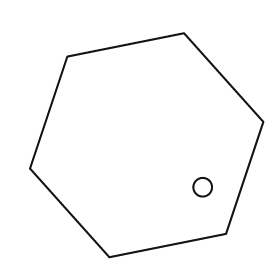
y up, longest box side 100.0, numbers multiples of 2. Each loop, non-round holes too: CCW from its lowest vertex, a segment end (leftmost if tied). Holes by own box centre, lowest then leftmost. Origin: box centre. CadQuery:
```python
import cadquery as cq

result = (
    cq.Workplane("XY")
    .moveTo(-16.0, -48.0)
    .lineTo(34.0, -38.0)
    .lineTo(50.0, 10.0)
    .lineTo(16.0, 48.0)
    .lineTo(-34.0, 38.0)
    .lineTo(-50.0, -10.0)
    .close()
    .moveTo(24.0, -18.0)
    .circle(4.0)
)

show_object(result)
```